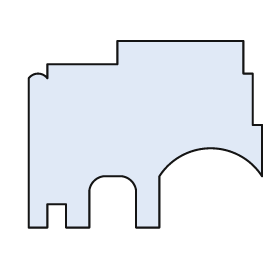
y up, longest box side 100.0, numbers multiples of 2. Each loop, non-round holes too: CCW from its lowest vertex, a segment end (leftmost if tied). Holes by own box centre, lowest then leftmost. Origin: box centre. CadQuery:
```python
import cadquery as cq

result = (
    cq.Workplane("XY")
    .moveTo(-50.0, -40.0)
    .lineTo(-42.0, -40.0)
    .lineTo(-42.0, -30.0)
    .lineTo(-34.0, -30.0)
    .lineTo(-34.0, -40.0)
    .lineTo(-24.0, -40.0)
    .lineTo(-24.0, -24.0)
    .threePointArc((-22.0, -20.0), (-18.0, -18.0))
    .lineTo(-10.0, -18.0)
    .threePointArc((-6.0, -20.0), (-4.0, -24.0))
    .lineTo(-4.0, -40.0)
    .lineTo(6.0, -40.0)
    .lineTo(6.0, -18.0)
    .threePointArc((28.0, -6.0), (50.0, -18.0))
    .lineTo(50.0, 4.0)
    .lineTo(46.0, 4.0)
    .lineTo(46.0, 26.0)
    .lineTo(42.0, 26.0)
    .lineTo(42.0, 40.0)
    .lineTo(-12.0, 40.0)
    .lineTo(-12.0, 30.0)
    .lineTo(-42.0, 30.0)
    .lineTo(-42.0, 24.0)
    .threePointArc((-46.0, 26.0), (-50.0, 24.0))
    .close()
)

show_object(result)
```